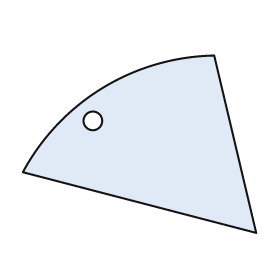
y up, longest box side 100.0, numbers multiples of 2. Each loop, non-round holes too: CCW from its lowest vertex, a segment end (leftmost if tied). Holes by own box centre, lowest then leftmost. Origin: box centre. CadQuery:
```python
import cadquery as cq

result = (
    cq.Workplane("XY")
    .moveTo(50.0, -38.0)
    .lineTo(32.0, 38.0)
    .threePointArc((-16.0, 24.0), (-50.0, -12.0))
    .close()
    .moveTo(-20.0, 10.0)
    .circle(4.0)
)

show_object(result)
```